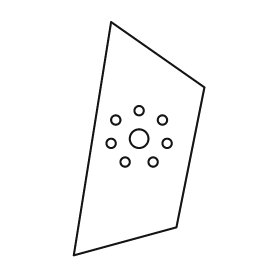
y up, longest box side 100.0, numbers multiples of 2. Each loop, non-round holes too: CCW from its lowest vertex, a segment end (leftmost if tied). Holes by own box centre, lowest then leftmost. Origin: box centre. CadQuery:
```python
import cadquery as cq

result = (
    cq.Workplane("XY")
    .moveTo(-28.0, -50.0)
    .lineTo(16.0, -38.0)
    .lineTo(28.0, 22.0)
    .lineTo(-12.0, 50.0)
    .close()
    .moveTo(-6.0, -10.0)
    .circle(2.0)
    .moveTo(6.0, -10.0)
    .circle(2.0)
    .moveTo(-12.0, -2.0)
    .circle(2.0)
    .moveTo(12.0, -2.0)
    .circle(2.0)
    .moveTo(0.0, 0.0)
    .circle(4.0)
    .moveTo(-10.0, 8.0)
    .circle(2.0)
    .moveTo(10.0, 8.0)
    .circle(2.0)
    .moveTo(0.0, 12.0)
    .circle(2.0)
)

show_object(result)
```